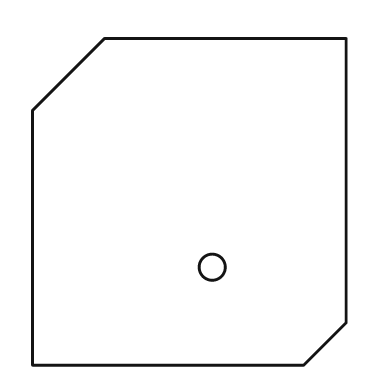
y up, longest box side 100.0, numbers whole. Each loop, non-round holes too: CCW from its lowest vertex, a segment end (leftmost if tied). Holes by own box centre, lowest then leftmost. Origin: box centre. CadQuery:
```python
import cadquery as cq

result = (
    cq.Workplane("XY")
    .moveTo(-48.0, -50.0)
    .lineTo(35.0, -50.0)
    .lineTo(48.0, -37.0)
    .lineTo(48.0, 50.0)
    .lineTo(-26.0, 50.0)
    .lineTo(-48.0, 28.0)
    .close()
    .moveTo(7.0, -20.0)
    .circle(4.0)
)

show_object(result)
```